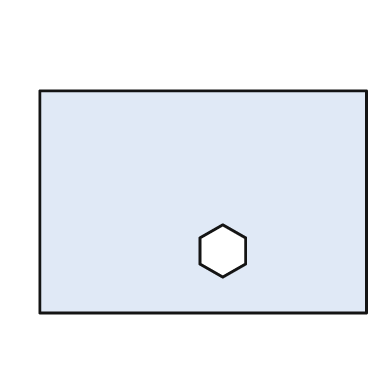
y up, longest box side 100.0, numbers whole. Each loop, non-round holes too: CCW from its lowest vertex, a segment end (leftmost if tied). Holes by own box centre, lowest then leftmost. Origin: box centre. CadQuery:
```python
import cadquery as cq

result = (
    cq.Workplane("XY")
    .moveTo(-50.0, -34.0)
    .lineTo(50.0, -34.0)
    .lineTo(50.0, 34.0)
    .lineTo(-50.0, 34.0)
    .close()
    .moveTo(6.0, -23.0)
    .lineTo(13.0, -19.0)
    .lineTo(13.0, -11.0)
    .lineTo(6.0, -7.0)
    .lineTo(-1.0, -11.0)
    .lineTo(-1.0, -19.0)
    .close()
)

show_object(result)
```